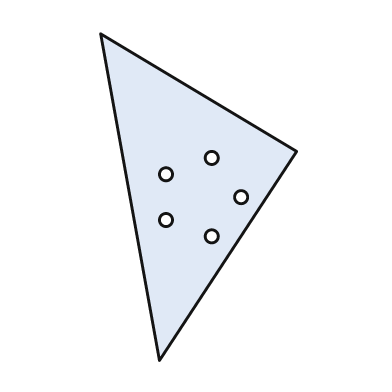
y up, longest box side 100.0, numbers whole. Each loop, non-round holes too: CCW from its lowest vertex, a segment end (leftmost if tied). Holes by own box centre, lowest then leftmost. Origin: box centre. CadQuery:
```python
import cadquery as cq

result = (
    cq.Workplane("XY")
    .moveTo(-12.0, -50.0)
    .lineTo(30.0, 14.0)
    .lineTo(-30.0, 50.0)
    .close()
    .moveTo(4.0, -12.0)
    .circle(2.0)
    .moveTo(-10.0, -7.0)
    .circle(2.0)
    .moveTo(13.0, 0.0)
    .circle(2.0)
    .moveTo(-10.0, 7.0)
    .circle(2.0)
    .moveTo(4.0, 12.0)
    .circle(2.0)
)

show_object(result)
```